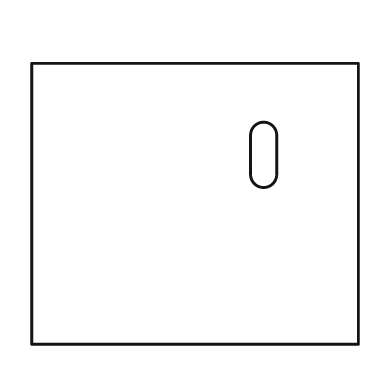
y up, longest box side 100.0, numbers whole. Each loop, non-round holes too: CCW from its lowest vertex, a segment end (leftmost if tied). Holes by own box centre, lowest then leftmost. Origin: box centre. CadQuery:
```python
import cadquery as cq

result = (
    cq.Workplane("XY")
    .moveTo(-50.0, -43.0)
    .lineTo(50.0, -43.0)
    .lineTo(50.0, 43.0)
    .lineTo(-50.0, 43.0)
    .close()
    .moveTo(17.0, 9.0)
    .threePointArc((21.0, 5.0), (25.0, 9.0))
    .lineTo(25.0, 21.0)
    .threePointArc((21.0, 25.0), (17.0, 21.0))
    .close()
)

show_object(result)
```